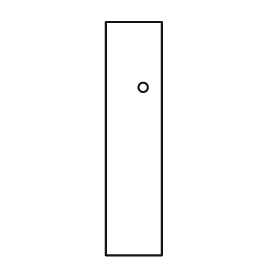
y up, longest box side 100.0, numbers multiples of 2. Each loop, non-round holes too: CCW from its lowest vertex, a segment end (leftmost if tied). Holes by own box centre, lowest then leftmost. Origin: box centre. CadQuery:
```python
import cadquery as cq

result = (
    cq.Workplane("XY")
    .moveTo(-12.0, -50.0)
    .lineTo(12.0, -50.0)
    .lineTo(12.0, 50.0)
    .lineTo(-12.0, 50.0)
    .close()
    .moveTo(4.0, 22.0)
    .circle(2.0)
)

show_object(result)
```